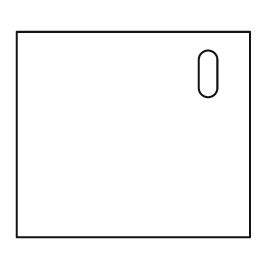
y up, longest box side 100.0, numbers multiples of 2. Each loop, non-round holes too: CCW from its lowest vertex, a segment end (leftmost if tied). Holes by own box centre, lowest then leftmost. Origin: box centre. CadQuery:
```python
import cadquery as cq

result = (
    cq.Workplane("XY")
    .moveTo(-50.0, -44.0)
    .lineTo(50.0, -44.0)
    .lineTo(50.0, 44.0)
    .lineTo(-50.0, 44.0)
    .close()
    .moveTo(28.0, 20.0)
    .threePointArc((32.0, 16.0), (36.0, 20.0))
    .lineTo(36.0, 32.0)
    .threePointArc((32.0, 36.0), (28.0, 32.0))
    .close()
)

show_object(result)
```